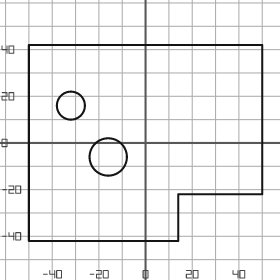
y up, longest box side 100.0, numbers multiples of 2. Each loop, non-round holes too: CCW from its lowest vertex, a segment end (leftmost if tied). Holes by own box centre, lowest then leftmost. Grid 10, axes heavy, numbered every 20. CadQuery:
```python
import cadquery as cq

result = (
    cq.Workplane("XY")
    .moveTo(-50.0, -42.0)
    .lineTo(14.0, -42.0)
    .lineTo(14.0, -22.0)
    .lineTo(50.0, -22.0)
    .lineTo(50.0, 42.0)
    .lineTo(-50.0, 42.0)
    .close()
    .moveTo(-16.0, -6.0)
    .circle(8.0)
    .moveTo(-32.0, 16.0)
    .circle(6.0)
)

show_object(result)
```